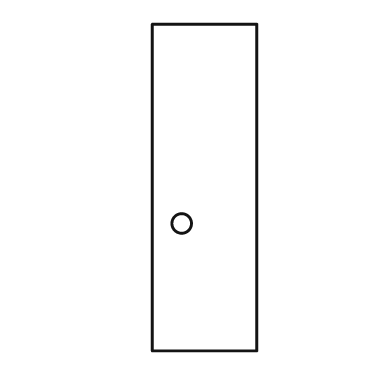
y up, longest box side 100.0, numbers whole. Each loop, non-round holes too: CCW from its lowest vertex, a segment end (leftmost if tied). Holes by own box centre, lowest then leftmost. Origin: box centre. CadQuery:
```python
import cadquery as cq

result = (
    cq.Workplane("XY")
    .moveTo(-16.0, -50.0)
    .lineTo(16.0, -50.0)
    .lineTo(16.0, 50.0)
    .lineTo(-16.0, 50.0)
    .close()
    .moveTo(-7.0, -11.0)
    .circle(3.0)
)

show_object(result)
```